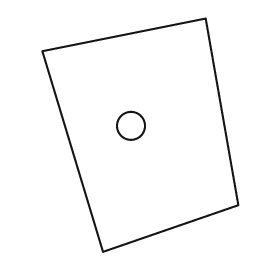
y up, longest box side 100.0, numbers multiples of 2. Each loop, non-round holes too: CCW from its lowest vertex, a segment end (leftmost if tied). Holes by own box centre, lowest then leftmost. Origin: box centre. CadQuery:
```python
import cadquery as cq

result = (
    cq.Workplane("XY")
    .moveTo(-16.0, -50.0)
    .lineTo(42.0, -30.0)
    .lineTo(28.0, 50.0)
    .lineTo(-42.0, 36.0)
    .close()
    .moveTo(-4.0, 4.0)
    .circle(6.0)
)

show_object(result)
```